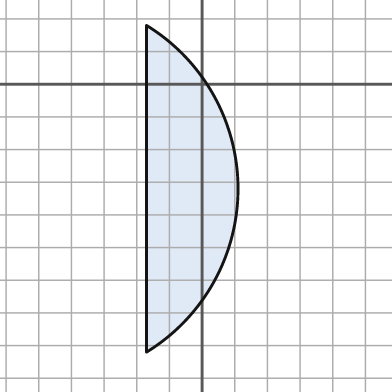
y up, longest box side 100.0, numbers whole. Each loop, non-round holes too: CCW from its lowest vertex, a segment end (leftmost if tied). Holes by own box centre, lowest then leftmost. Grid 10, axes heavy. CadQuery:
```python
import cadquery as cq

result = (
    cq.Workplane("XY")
    .moveTo(-17.0, -82.0)
    .threePointArc((11.0, -32.0), (-17.0, 18.0))
    .close()
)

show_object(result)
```